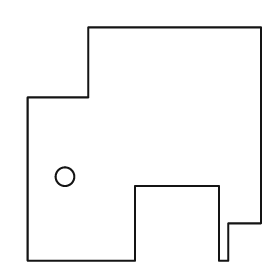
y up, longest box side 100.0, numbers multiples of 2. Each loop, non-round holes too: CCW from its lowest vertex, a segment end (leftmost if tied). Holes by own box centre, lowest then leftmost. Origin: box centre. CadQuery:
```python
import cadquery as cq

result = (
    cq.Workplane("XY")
    .moveTo(-50.0, -50.0)
    .lineTo(-4.0, -50.0)
    .lineTo(-4.0, -18.0)
    .lineTo(32.0, -18.0)
    .lineTo(32.0, -50.0)
    .lineTo(36.0, -50.0)
    .lineTo(36.0, -34.0)
    .lineTo(50.0, -34.0)
    .lineTo(50.0, 50.0)
    .lineTo(-24.0, 50.0)
    .lineTo(-24.0, 20.0)
    .lineTo(-50.0, 20.0)
    .close()
    .moveTo(-34.0, -14.0)
    .circle(4.0)
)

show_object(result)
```